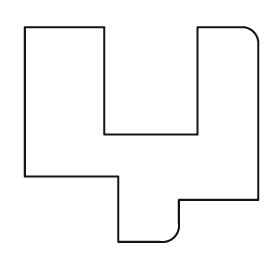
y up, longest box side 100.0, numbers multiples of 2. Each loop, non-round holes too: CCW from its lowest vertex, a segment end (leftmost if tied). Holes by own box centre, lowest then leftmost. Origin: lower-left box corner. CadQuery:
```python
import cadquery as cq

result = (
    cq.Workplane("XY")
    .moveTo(40.0, 0.0)
    .lineTo(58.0, 0.0)
    .threePointArc((64.0, 2.0), (66.0, 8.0))
    .lineTo(66.0, 18.0)
    .lineTo(100.0, 18.0)
    .lineTo(100.0, 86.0)
    .threePointArc((98.0, 90.0), (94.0, 92.0))
    .lineTo(74.0, 92.0)
    .lineTo(74.0, 46.0)
    .lineTo(34.0, 46.0)
    .lineTo(34.0, 92.0)
    .lineTo(0.0, 92.0)
    .lineTo(0.0, 28.0)
    .lineTo(40.0, 28.0)
    .close()
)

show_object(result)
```